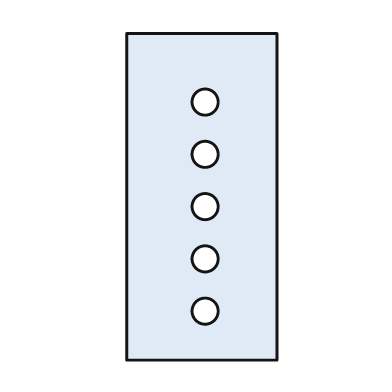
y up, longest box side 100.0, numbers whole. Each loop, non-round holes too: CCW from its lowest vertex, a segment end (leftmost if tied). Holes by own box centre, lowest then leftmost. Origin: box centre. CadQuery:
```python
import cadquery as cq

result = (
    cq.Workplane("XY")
    .moveTo(-23.0, -50.0)
    .lineTo(23.0, -50.0)
    .lineTo(23.0, 50.0)
    .lineTo(-23.0, 50.0)
    .close()
    .moveTo(1.0, -35.0)
    .circle(4.0)
    .moveTo(1.0, -19.0)
    .circle(4.0)
    .moveTo(1.0, -3.0)
    .circle(4.0)
    .moveTo(1.0, 13.0)
    .circle(4.0)
    .moveTo(1.0, 29.0)
    .circle(4.0)
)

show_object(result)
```